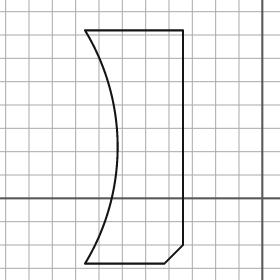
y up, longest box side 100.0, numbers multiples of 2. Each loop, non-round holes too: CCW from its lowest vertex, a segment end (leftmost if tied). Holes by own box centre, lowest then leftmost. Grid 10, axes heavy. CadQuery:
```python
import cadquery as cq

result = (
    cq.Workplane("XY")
    .moveTo(-76.0, -28.0)
    .lineTo(-42.0, -28.0)
    .lineTo(-34.0, -20.0)
    .lineTo(-34.0, 72.0)
    .lineTo(-76.0, 72.0)
    .threePointArc((-62.0, 22.0), (-76.0, -28.0))
    .close()
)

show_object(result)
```